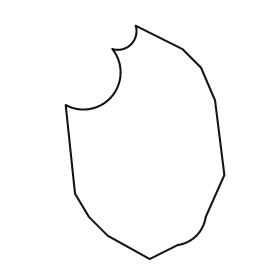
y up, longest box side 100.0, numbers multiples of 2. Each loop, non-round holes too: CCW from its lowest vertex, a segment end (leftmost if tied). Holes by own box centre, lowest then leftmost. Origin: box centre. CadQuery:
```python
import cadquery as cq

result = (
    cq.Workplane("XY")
    .moveTo(2.0, -50.0)
    .lineTo(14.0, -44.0)
    .threePointArc((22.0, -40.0), (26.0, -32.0))
    .lineTo(34.0, -14.0)
    .lineTo(30.0, 18.0)
    .lineTo(24.0, 32.0)
    .lineTo(16.0, 40.0)
    .lineTo(-4.0, 50.0)
    .threePointArc((-6.0, 42.0), (-14.0, 40.0))
    .threePointArc((-14.0, 20.0), (-34.0, 16.0))
    .lineTo(-30.0, -22.0)
    .lineTo(-24.0, -32.0)
    .lineTo(-16.0, -40.0)
    .close()
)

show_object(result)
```